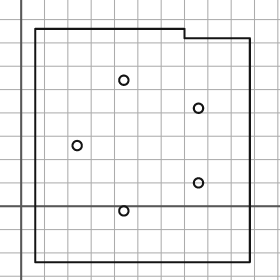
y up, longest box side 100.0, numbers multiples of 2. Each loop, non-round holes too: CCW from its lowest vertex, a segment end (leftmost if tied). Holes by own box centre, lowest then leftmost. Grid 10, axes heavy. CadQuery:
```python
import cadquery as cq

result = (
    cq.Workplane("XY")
    .moveTo(6.0, -24.0)
    .lineTo(98.0, -24.0)
    .lineTo(98.0, 72.0)
    .lineTo(70.0, 72.0)
    .lineTo(70.0, 76.0)
    .lineTo(6.0, 76.0)
    .close()
    .moveTo(44.0, -2.0)
    .circle(2.0)
    .moveTo(76.0, 10.0)
    .circle(2.0)
    .moveTo(24.0, 26.0)
    .circle(2.0)
    .moveTo(76.0, 42.0)
    .circle(2.0)
    .moveTo(44.0, 54.0)
    .circle(2.0)
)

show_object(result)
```